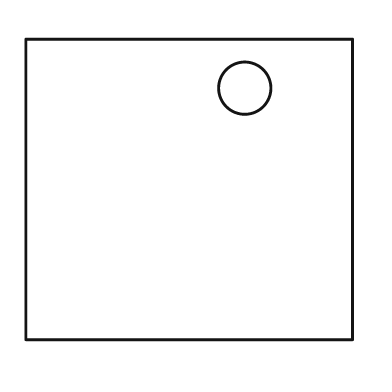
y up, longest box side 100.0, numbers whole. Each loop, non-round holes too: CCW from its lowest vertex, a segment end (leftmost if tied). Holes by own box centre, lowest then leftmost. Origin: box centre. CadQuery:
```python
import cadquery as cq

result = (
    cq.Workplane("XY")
    .moveTo(-50.0, -46.0)
    .lineTo(50.0, -46.0)
    .lineTo(50.0, 46.0)
    .lineTo(-50.0, 46.0)
    .close()
    .moveTo(17.0, 31.0)
    .circle(8.0)
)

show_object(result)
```